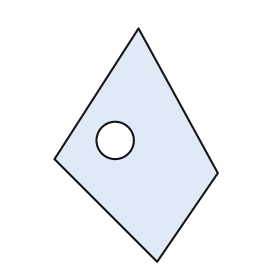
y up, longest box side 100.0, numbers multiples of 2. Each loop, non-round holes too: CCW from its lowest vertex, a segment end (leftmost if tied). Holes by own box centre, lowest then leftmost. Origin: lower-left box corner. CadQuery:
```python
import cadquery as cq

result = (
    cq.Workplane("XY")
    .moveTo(44.0, 0.0)
    .lineTo(70.0, 38.0)
    .lineTo(36.0, 100.0)
    .lineTo(0.0, 44.0)
    .close()
    .moveTo(26.0, 52.0)
    .circle(8.0)
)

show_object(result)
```